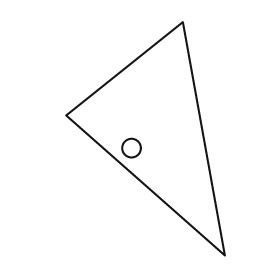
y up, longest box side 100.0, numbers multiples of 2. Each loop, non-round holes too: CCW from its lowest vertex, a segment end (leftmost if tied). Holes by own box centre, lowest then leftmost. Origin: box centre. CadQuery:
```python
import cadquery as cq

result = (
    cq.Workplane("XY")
    .moveTo(34.0, -50.0)
    .lineTo(16.0, 50.0)
    .lineTo(-34.0, 10.0)
    .close()
    .moveTo(-6.0, -4.0)
    .circle(4.0)
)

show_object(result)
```